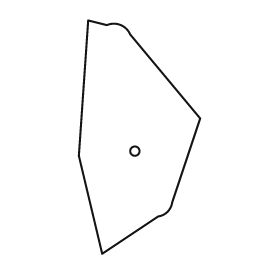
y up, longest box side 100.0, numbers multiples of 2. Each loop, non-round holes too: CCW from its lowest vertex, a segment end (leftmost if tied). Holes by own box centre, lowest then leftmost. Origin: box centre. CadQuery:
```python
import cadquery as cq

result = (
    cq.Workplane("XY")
    .moveTo(-16.0, -50.0)
    .lineTo(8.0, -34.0)
    .threePointArc((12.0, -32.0), (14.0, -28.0))
    .lineTo(26.0, 8.0)
    .lineTo(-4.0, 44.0)
    .threePointArc((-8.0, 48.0), (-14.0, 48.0))
    .lineTo(-22.0, 50.0)
    .lineTo(-26.0, -8.0)
    .close()
    .moveTo(-2.0, -6.0)
    .circle(2.0)
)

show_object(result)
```